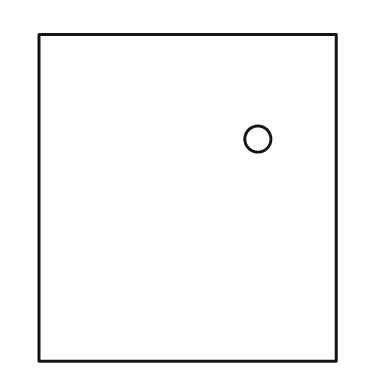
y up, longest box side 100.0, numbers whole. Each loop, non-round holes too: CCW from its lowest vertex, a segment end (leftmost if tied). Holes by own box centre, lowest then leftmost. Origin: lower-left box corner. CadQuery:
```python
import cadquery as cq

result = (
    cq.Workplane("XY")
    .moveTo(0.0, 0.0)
    .lineTo(91.0, 0.0)
    .lineTo(91.0, 100.0)
    .lineTo(0.0, 100.0)
    .close()
    .moveTo(67.0, 68.0)
    .circle(4.0)
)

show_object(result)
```